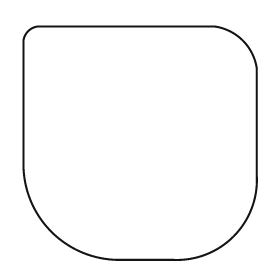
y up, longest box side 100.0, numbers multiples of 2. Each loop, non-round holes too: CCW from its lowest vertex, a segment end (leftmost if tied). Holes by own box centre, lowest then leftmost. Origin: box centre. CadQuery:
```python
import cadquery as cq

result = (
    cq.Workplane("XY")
    .moveTo(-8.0, -50.0)
    .lineTo(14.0, -50.0)
    .threePointArc((40.0, -40.0), (50.0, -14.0))
    .lineTo(50.0, 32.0)
    .threePointArc((44.0, 44.0), (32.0, 50.0))
    .lineTo(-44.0, 50.0)
    .threePointArc((-48.0, 48.0), (-50.0, 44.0))
    .lineTo(-50.0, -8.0)
    .threePointArc((-38.0, -38.0), (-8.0, -50.0))
    .close()
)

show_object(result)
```